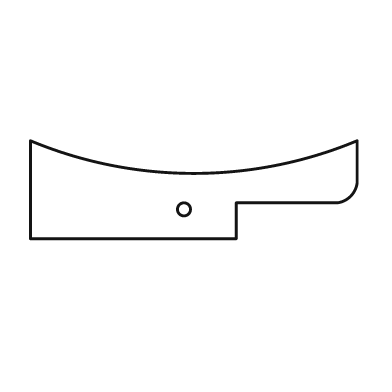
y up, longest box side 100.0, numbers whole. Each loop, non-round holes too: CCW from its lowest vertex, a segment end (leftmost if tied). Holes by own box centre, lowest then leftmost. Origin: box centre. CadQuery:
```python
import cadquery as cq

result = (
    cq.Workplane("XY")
    .moveTo(-50.0, -15.0)
    .lineTo(13.0, -15.0)
    .lineTo(13.0, -4.0)
    .lineTo(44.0, -4.0)
    .threePointArc((48.0, -2.0), (50.0, 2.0))
    .lineTo(50.0, 15.0)
    .threePointArc((0.0, 5.0), (-50.0, 15.0))
    .close()
    .moveTo(-3.0, -6.0)
    .circle(2.0)
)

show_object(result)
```